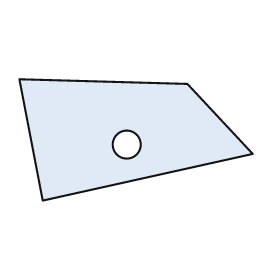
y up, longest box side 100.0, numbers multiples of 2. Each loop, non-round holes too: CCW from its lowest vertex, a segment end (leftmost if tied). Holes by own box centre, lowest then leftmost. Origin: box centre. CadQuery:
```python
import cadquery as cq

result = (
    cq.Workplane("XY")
    .moveTo(-40.0, -26.0)
    .lineTo(50.0, -6.0)
    .lineTo(22.0, 24.0)
    .lineTo(-50.0, 26.0)
    .close()
    .moveTo(-4.0, -2.0)
    .circle(6.0)
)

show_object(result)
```